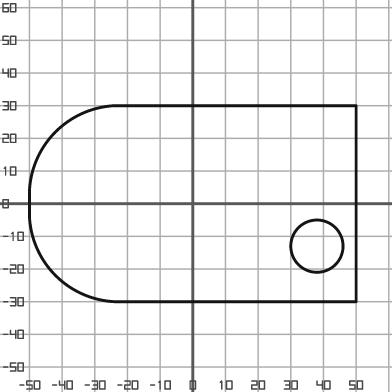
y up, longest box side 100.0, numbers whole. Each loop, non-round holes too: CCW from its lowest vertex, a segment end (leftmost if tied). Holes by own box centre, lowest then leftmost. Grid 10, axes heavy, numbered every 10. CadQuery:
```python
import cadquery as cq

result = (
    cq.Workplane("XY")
    .moveTo(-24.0, -30.0)
    .lineTo(50.0, -30.0)
    .lineTo(50.0, 30.0)
    .lineTo(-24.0, 30.0)
    .threePointArc((-42.0, 22.0), (-50.0, 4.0))
    .lineTo(-50.0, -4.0)
    .threePointArc((-42.0, -22.0), (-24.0, -30.0))
    .close()
    .moveTo(38.0, -13.0)
    .circle(8.0)
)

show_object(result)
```